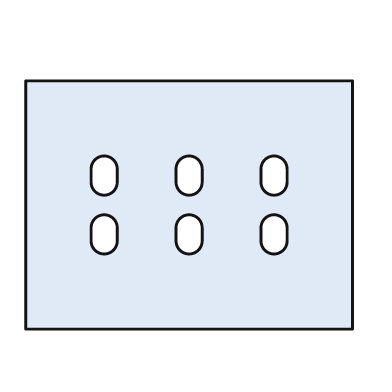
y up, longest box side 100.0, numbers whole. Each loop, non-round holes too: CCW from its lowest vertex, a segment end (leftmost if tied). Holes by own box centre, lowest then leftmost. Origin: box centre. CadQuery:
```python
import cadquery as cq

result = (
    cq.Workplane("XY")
    .moveTo(-50.0, -38.0)
    .lineTo(50.0, -38.0)
    .lineTo(50.0, 38.0)
    .lineTo(-50.0, 38.0)
    .close()
    .moveTo(-30.0, -11.0)
    .threePointArc((-26.0, -15.0), (-22.0, -11.0))
    .lineTo(-22.0, -7.0)
    .threePointArc((-26.0, -3.0), (-30.0, -7.0))
    .close()
    .moveTo(-4.0, -11.0)
    .threePointArc((0.0, -15.0), (4.0, -11.0))
    .lineTo(4.0, -7.0)
    .threePointArc((0.0, -3.0), (-4.0, -7.0))
    .close()
    .moveTo(22.0, -11.0)
    .threePointArc((26.0, -15.0), (30.0, -11.0))
    .lineTo(30.0, -7.0)
    .threePointArc((26.0, -3.0), (22.0, -7.0))
    .close()
    .moveTo(-30.0, 7.0)
    .threePointArc((-26.0, 3.0), (-22.0, 7.0))
    .lineTo(-22.0, 11.0)
    .threePointArc((-26.0, 15.0), (-30.0, 11.0))
    .close()
    .moveTo(-4.0, 7.0)
    .threePointArc((0.0, 3.0), (4.0, 7.0))
    .lineTo(4.0, 11.0)
    .threePointArc((0.0, 15.0), (-4.0, 11.0))
    .close()
    .moveTo(22.0, 7.0)
    .threePointArc((26.0, 3.0), (30.0, 7.0))
    .lineTo(30.0, 11.0)
    .threePointArc((26.0, 15.0), (22.0, 11.0))
    .close()
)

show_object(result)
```